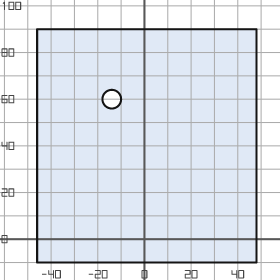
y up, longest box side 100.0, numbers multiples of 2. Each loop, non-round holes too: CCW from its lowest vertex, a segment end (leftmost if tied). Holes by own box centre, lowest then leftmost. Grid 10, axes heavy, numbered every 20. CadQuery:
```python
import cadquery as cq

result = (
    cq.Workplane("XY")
    .moveTo(-46.0, -10.0)
    .lineTo(48.0, -10.0)
    .lineTo(48.0, 90.0)
    .lineTo(-46.0, 90.0)
    .close()
    .moveTo(-14.0, 60.0)
    .circle(4.0)
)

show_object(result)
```